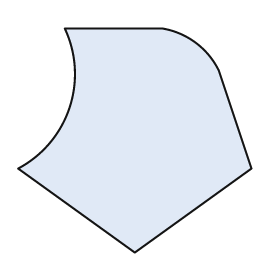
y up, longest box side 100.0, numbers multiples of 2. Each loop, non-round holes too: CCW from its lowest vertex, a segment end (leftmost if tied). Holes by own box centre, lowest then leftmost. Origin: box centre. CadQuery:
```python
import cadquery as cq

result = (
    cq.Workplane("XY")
    .moveTo(0.0, -48.0)
    .lineTo(50.0, -12.0)
    .lineTo(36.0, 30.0)
    .threePointArc((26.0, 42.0), (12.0, 48.0))
    .lineTo(-30.0, 48.0)
    .threePointArc((-28.0, 14.0), (-50.0, -12.0))
    .close()
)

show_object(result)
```